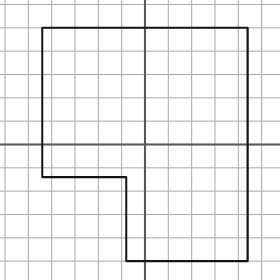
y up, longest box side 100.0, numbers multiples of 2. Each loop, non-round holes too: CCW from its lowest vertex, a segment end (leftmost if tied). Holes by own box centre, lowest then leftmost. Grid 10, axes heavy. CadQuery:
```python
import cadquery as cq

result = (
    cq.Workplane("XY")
    .moveTo(-8.0, -50.0)
    .lineTo(44.0, -50.0)
    .lineTo(44.0, 50.0)
    .lineTo(-44.0, 50.0)
    .lineTo(-44.0, -14.0)
    .lineTo(-8.0, -14.0)
    .close()
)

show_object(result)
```